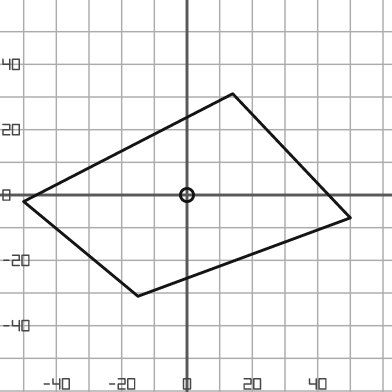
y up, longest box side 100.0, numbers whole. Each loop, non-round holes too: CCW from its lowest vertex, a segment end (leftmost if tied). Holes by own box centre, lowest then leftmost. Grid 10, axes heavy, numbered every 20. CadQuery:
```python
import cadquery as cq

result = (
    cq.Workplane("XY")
    .moveTo(-15.0, -31.0)
    .lineTo(50.0, -7.0)
    .lineTo(14.0, 31.0)
    .lineTo(-50.0, -2.0)
    .close()
    .moveTo(0.0, 0.0)
    .circle(2.0)
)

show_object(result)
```